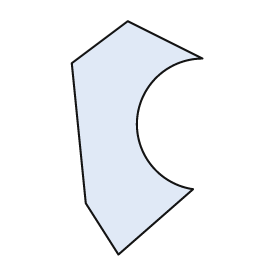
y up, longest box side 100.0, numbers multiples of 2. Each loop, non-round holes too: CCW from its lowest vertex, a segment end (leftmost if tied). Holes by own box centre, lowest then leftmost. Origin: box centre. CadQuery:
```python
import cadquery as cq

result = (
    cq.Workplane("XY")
    .moveTo(-8.0, -50.0)
    .lineTo(24.0, -22.0)
    .threePointArc((0.0, 8.0), (28.0, 34.0))
    .lineTo(-4.0, 50.0)
    .lineTo(-28.0, 32.0)
    .lineTo(-22.0, -28.0)
    .close()
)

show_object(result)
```